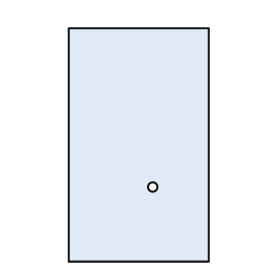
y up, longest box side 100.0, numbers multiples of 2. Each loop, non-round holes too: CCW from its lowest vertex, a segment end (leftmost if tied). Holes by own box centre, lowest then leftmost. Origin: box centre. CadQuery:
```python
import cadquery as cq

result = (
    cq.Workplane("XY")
    .moveTo(-30.0, -50.0)
    .lineTo(30.0, -50.0)
    .lineTo(30.0, 50.0)
    .lineTo(-30.0, 50.0)
    .close()
    .moveTo(6.0, -18.0)
    .circle(2.0)
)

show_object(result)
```